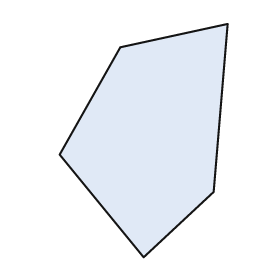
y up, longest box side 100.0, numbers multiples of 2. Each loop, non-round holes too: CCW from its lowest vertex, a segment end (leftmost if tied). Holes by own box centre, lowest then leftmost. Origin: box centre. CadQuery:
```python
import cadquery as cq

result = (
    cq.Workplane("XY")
    .moveTo(0.0, -50.0)
    .lineTo(30.0, -22.0)
    .lineTo(36.0, 50.0)
    .lineTo(-10.0, 40.0)
    .lineTo(-36.0, -6.0)
    .close()
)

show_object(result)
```